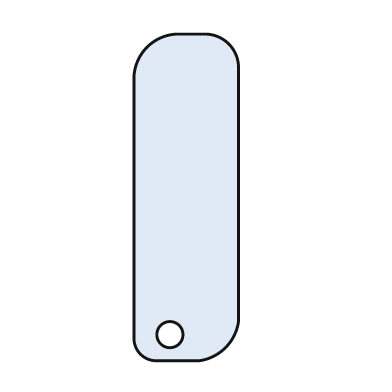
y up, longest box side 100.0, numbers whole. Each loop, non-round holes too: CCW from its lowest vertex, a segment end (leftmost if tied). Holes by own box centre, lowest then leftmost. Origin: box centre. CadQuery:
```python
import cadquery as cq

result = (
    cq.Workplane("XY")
    .moveTo(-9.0, -50.0)
    .lineTo(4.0, -50.0)
    .threePointArc((12.0, -46.0), (16.0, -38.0))
    .lineTo(16.0, 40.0)
    .threePointArc((13.0, 47.0), (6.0, 50.0))
    .lineTo(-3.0, 50.0)
    .threePointArc((-12.0, 46.0), (-16.0, 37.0))
    .lineTo(-16.0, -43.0)
    .threePointArc((-14.0, -48.0), (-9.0, -50.0))
    .close()
    .moveTo(-5.0, -42.0)
    .circle(4.0)
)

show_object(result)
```